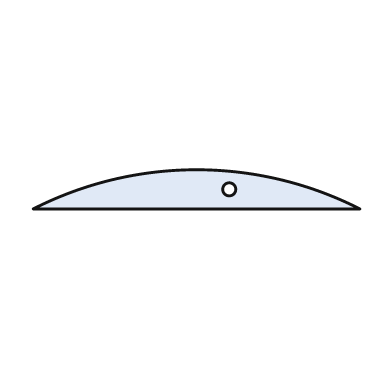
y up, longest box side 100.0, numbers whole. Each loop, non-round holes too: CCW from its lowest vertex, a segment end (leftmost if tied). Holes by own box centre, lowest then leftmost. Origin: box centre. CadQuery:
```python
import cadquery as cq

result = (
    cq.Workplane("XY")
    .moveTo(-50.0, -6.0)
    .lineTo(50.0, -6.0)
    .threePointArc((0.0, 6.0), (-50.0, -6.0))
    .close()
    .moveTo(10.0, 0.0)
    .circle(2.0)
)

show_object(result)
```